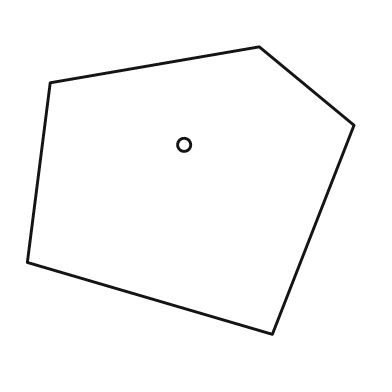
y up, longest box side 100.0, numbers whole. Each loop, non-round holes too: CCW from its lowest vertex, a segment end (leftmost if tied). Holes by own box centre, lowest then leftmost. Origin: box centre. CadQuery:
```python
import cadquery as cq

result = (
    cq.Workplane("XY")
    .moveTo(25.0, -44.0)
    .lineTo(50.0, 20.0)
    .lineTo(21.0, 44.0)
    .lineTo(-43.0, 33.0)
    .lineTo(-50.0, -22.0)
    .close()
    .moveTo(-2.0, 14.0)
    .circle(2.0)
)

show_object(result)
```